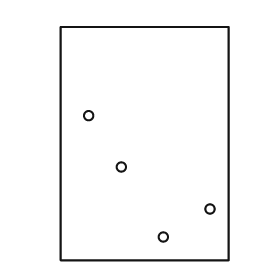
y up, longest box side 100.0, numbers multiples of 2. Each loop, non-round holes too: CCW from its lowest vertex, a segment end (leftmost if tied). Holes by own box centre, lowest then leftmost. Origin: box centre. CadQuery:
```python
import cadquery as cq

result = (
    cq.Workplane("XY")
    .moveTo(-36.0, -50.0)
    .lineTo(36.0, -50.0)
    .lineTo(36.0, 50.0)
    .lineTo(-36.0, 50.0)
    .close()
    .moveTo(8.0, -40.0)
    .circle(2.0)
    .moveTo(28.0, -28.0)
    .circle(2.0)
    .moveTo(-10.0, -10.0)
    .circle(2.0)
    .moveTo(-24.0, 12.0)
    .circle(2.0)
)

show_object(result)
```